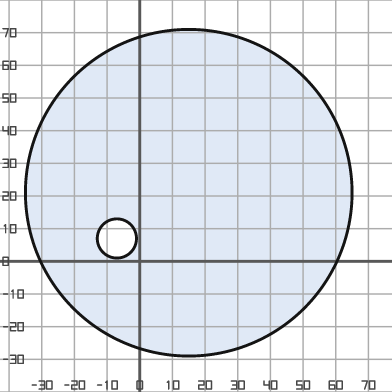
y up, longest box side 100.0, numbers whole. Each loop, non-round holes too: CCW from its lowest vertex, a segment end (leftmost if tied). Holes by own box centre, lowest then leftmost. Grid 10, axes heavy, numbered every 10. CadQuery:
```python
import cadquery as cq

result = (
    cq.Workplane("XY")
    .moveTo(15.0, 21.0)
    .circle(50.0)
    .moveTo(-7.0, 7.0)
    .circle(6.0)
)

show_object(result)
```